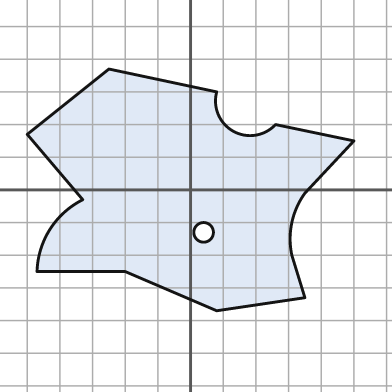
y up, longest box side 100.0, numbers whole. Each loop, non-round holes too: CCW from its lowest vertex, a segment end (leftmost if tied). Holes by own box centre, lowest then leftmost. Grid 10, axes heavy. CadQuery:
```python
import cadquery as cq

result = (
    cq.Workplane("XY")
    .moveTo(8.0, -37.0)
    .lineTo(35.0, -33.0)
    .lineTo(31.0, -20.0)
    .threePointArc((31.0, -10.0), (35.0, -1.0))
    .lineTo(50.0, 15.0)
    .lineTo(26.0, 20.0)
    .threePointArc((13.0, 18.0), (8.0, 30.0))
    .lineTo(-25.0, 37.0)
    .lineTo(-50.0, 17.0)
    .lineTo(-33.0, -3.0)
    .threePointArc((-43.0, -12.0), (-47.0, -25.0))
    .lineTo(-20.0, -25.0)
    .close()
    .moveTo(4.0, -13.0)
    .circle(3.0)
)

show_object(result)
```